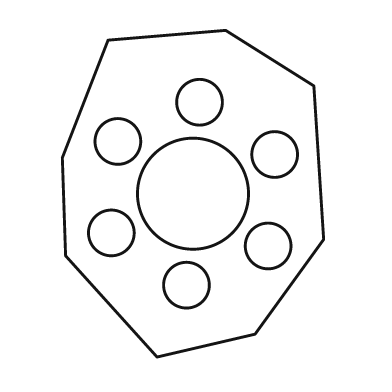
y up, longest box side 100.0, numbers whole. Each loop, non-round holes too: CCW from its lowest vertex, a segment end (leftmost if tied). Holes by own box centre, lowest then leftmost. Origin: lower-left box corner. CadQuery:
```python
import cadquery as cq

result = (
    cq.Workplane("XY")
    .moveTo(29.0, 0.0)
    .lineTo(59.0, 7.0)
    .lineTo(80.0, 36.0)
    .lineTo(77.0, 83.0)
    .lineTo(50.0, 100.0)
    .lineTo(14.0, 97.0)
    .lineTo(0.0, 61.0)
    .lineTo(1.0, 31.0)
    .close()
    .moveTo(38.0, 22.0)
    .circle(7.0)
    .moveTo(63.0, 34.0)
    .circle(7.0)
    .moveTo(15.0, 38.0)
    .circle(7.0)
    .moveTo(40.0, 50.0)
    .circle(17.0)
    .moveTo(65.0, 62.0)
    .circle(7.0)
    .moveTo(17.0, 66.0)
    .circle(7.0)
    .moveTo(42.0, 78.0)
    .circle(7.0)
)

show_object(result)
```